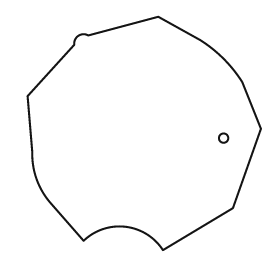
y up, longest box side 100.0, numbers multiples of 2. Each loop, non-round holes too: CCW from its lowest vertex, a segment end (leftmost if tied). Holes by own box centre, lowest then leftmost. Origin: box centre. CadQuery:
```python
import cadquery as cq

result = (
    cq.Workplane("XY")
    .moveTo(8.0, -50.0)
    .lineTo(38.0, -32.0)
    .lineTo(50.0, 2.0)
    .lineTo(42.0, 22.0)
    .threePointArc((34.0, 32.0), (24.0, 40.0))
    .lineTo(6.0, 50.0)
    .lineTo(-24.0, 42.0)
    .threePointArc((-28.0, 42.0), (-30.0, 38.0))
    .lineTo(-50.0, 16.0)
    .lineTo(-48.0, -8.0)
    .threePointArc((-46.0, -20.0), (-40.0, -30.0))
    .lineTo(-26.0, -46.0)
    .threePointArc((-8.0, -40.0), (8.0, -50.0))
    .close()
    .moveTo(34.0, -2.0)
    .circle(2.0)
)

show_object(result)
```